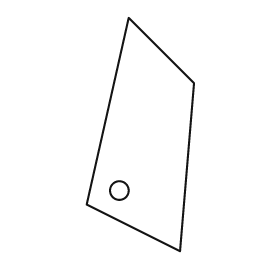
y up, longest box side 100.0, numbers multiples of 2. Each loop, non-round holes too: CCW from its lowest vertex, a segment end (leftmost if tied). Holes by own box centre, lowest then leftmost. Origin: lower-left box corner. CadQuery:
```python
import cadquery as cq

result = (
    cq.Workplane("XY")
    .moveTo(40.0, 0.0)
    .lineTo(46.0, 72.0)
    .lineTo(18.0, 100.0)
    .lineTo(0.0, 20.0)
    .close()
    .moveTo(14.0, 26.0)
    .circle(4.0)
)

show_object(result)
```